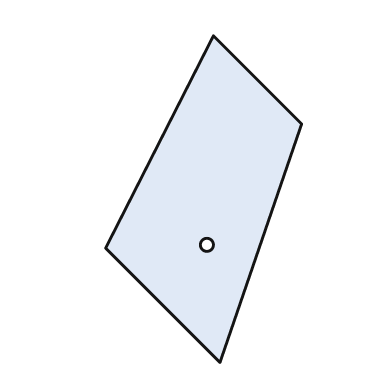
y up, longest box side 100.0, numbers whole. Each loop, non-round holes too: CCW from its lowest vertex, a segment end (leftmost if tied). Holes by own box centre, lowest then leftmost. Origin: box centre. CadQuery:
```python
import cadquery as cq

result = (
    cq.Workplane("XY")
    .moveTo(5.0, -50.0)
    .lineTo(30.0, 23.0)
    .lineTo(3.0, 50.0)
    .lineTo(-30.0, -15.0)
    .close()
    .moveTo(1.0, -14.0)
    .circle(2.0)
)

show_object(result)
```